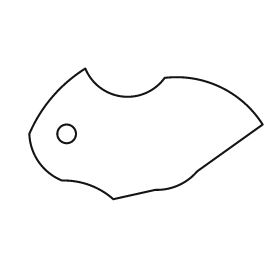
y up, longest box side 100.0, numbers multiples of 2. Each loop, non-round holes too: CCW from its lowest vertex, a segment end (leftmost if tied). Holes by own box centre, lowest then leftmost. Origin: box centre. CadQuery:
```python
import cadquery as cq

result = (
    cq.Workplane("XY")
    .moveTo(-14.0, -28.0)
    .lineTo(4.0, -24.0)
    .threePointArc((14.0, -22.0), (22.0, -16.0))
    .lineTo(50.0, 4.0)
    .threePointArc((32.0, 20.0), (8.0, 24.0))
    .threePointArc((-10.0, 16.0), (-26.0, 28.0))
    .threePointArc((-40.0, 16.0), (-50.0, 0.0))
    .threePointArc((-46.0, -12.0), (-36.0, -20.0))
    .threePointArc((-24.0, -22.0), (-14.0, -28.0))
    .close()
    .moveTo(-34.0, 0.0)
    .circle(4.0)
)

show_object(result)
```